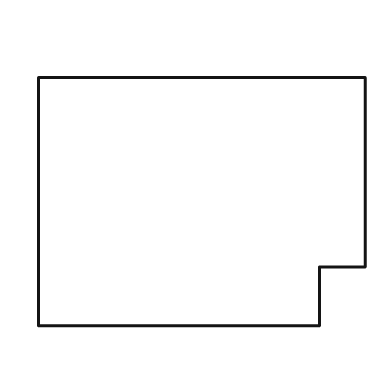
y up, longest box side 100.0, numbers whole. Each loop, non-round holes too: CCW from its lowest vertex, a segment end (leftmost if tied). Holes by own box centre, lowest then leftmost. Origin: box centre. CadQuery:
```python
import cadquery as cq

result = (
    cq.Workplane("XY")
    .moveTo(-50.0, -38.0)
    .lineTo(36.0, -38.0)
    .lineTo(36.0, -20.0)
    .lineTo(50.0, -20.0)
    .lineTo(50.0, 38.0)
    .lineTo(-50.0, 38.0)
    .close()
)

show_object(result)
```